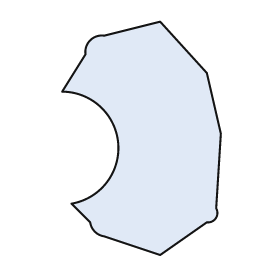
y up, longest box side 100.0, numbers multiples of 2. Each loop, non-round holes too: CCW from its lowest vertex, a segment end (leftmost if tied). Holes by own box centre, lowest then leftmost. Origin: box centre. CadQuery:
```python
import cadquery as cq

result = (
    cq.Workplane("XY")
    .moveTo(8.0, -50.0)
    .lineTo(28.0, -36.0)
    .threePointArc((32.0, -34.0), (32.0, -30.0))
    .lineTo(34.0, 2.0)
    .lineTo(28.0, 28.0)
    .lineTo(8.0, 50.0)
    .lineTo(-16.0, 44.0)
    .threePointArc((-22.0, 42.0), (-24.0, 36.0))
    .lineTo(-34.0, 20.0)
    .threePointArc((-10.0, -2.0), (-30.0, -28.0))
    .lineTo(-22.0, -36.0)
    .threePointArc((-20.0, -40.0), (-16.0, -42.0))
    .close()
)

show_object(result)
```